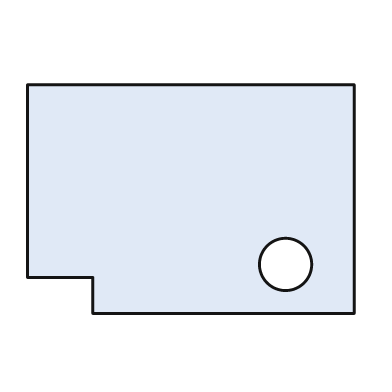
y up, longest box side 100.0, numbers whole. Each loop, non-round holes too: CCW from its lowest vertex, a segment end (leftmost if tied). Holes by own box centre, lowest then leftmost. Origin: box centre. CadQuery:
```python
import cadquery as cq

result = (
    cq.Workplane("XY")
    .moveTo(-30.0, -35.0)
    .lineTo(50.0, -35.0)
    .lineTo(50.0, 35.0)
    .lineTo(-50.0, 35.0)
    .lineTo(-50.0, -24.0)
    .lineTo(-30.0, -24.0)
    .close()
    .moveTo(29.0, -20.0)
    .circle(8.0)
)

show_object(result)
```